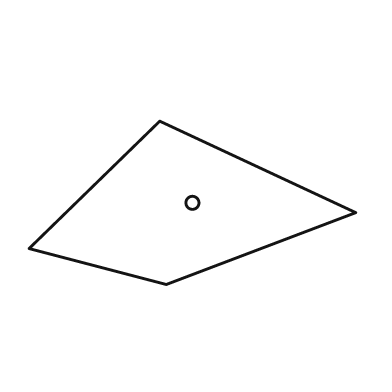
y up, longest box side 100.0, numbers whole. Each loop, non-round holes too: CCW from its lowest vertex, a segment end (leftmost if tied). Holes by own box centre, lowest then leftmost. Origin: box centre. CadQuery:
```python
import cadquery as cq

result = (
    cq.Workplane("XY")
    .moveTo(-8.0, -25.0)
    .lineTo(50.0, -3.0)
    .lineTo(-10.0, 25.0)
    .lineTo(-50.0, -14.0)
    .close()
    .moveTo(0.0, 0.0)
    .circle(2.0)
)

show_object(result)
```